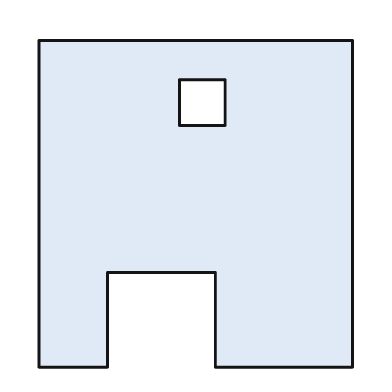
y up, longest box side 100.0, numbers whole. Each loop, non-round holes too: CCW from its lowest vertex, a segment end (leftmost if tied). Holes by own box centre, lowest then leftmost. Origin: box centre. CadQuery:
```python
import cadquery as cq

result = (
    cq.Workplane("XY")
    .moveTo(-48.0, -50.0)
    .lineTo(-27.0, -50.0)
    .lineTo(-27.0, -21.0)
    .lineTo(6.0, -21.0)
    .lineTo(6.0, -50.0)
    .lineTo(48.0, -50.0)
    .lineTo(48.0, 50.0)
    .lineTo(-48.0, 50.0)
    .close()
    .moveTo(-5.0, 24.0)
    .lineTo(9.0, 24.0)
    .lineTo(9.0, 38.0)
    .lineTo(-5.0, 38.0)
    .close()
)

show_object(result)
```